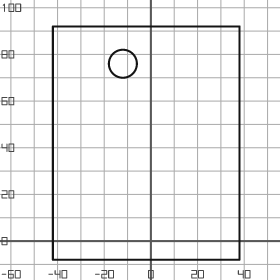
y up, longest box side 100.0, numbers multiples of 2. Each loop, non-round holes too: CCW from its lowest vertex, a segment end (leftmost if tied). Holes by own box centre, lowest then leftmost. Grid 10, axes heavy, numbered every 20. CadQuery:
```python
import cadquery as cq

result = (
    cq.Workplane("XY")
    .moveTo(-42.0, -8.0)
    .lineTo(38.0, -8.0)
    .lineTo(38.0, 92.0)
    .lineTo(-42.0, 92.0)
    .close()
    .moveTo(-12.0, 76.0)
    .circle(6.0)
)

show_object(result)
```